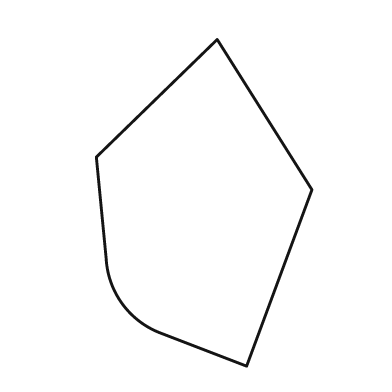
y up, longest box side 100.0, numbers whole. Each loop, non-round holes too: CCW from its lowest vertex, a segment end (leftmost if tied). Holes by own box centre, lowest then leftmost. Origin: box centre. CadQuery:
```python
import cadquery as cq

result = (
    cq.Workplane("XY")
    .moveTo(13.0, -50.0)
    .lineTo(33.0, 4.0)
    .lineTo(4.0, 50.0)
    .lineTo(-33.0, 14.0)
    .lineTo(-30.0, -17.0)
    .threePointArc((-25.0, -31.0), (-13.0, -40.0))
    .close()
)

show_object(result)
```